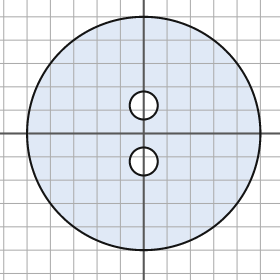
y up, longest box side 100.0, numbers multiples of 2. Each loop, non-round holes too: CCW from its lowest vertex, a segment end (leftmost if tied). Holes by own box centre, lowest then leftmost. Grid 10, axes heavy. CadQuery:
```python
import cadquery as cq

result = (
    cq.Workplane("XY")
    .moveTo(0.0, 0.0)
    .circle(50.0)
    .moveTo(0.0, -12.0)
    .circle(6.0)
    .moveTo(0.0, 12.0)
    .circle(6.0)
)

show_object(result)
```